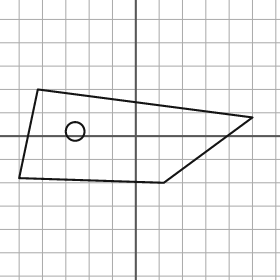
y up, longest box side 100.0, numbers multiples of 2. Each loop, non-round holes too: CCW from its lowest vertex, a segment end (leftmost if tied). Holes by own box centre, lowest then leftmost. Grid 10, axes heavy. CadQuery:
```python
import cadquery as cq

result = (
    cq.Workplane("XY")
    .moveTo(12.0, -20.0)
    .lineTo(50.0, 8.0)
    .lineTo(-42.0, 20.0)
    .lineTo(-50.0, -18.0)
    .close()
    .moveTo(-26.0, 2.0)
    .circle(4.0)
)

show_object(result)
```